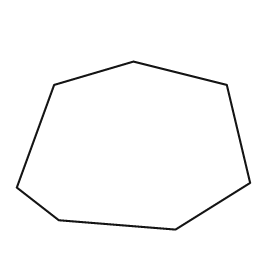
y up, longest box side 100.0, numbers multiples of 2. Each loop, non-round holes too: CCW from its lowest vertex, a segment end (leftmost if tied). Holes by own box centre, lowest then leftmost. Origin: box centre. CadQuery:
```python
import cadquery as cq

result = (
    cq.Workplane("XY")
    .moveTo(18.0, -36.0)
    .lineTo(50.0, -16.0)
    .lineTo(40.0, 26.0)
    .lineTo(0.0, 36.0)
    .lineTo(-34.0, 26.0)
    .lineTo(-50.0, -18.0)
    .lineTo(-32.0, -32.0)
    .close()
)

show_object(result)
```